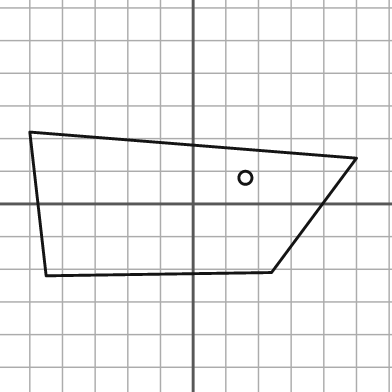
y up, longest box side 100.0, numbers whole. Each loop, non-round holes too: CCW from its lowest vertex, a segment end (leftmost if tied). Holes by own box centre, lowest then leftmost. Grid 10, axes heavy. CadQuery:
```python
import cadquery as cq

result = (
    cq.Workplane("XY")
    .moveTo(-45.0, -22.0)
    .lineTo(24.0, -21.0)
    .lineTo(50.0, 14.0)
    .lineTo(-50.0, 22.0)
    .close()
    .moveTo(16.0, 8.0)
    .circle(2.0)
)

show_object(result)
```